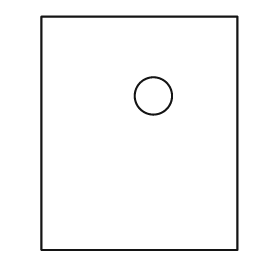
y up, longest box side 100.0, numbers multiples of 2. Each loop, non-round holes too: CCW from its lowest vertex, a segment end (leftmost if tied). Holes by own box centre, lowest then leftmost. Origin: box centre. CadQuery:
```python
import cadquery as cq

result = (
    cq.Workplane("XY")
    .moveTo(-42.0, -50.0)
    .lineTo(42.0, -50.0)
    .lineTo(42.0, 50.0)
    .lineTo(-42.0, 50.0)
    .close()
    .moveTo(6.0, 16.0)
    .circle(8.0)
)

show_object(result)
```